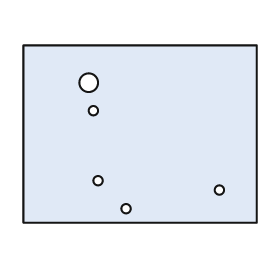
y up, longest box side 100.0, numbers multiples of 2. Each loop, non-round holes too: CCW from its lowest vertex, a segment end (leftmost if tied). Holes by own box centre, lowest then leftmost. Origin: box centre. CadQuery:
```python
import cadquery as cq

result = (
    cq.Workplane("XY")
    .moveTo(-50.0, -38.0)
    .lineTo(50.0, -38.0)
    .lineTo(50.0, 38.0)
    .lineTo(-50.0, 38.0)
    .close()
    .moveTo(-6.0, -32.0)
    .circle(2.0)
    .moveTo(34.0, -24.0)
    .circle(2.0)
    .moveTo(-18.0, -20.0)
    .circle(2.0)
    .moveTo(-20.0, 10.0)
    .circle(2.0)
    .moveTo(-22.0, 22.0)
    .circle(4.0)
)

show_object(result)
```